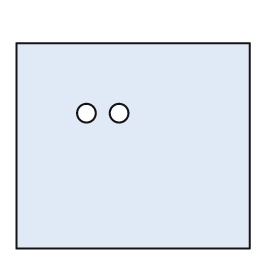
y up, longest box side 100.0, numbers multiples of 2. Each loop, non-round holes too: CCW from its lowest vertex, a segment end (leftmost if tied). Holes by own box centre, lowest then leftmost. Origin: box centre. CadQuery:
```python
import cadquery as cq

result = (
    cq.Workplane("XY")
    .moveTo(-50.0, -44.0)
    .lineTo(50.0, -44.0)
    .lineTo(50.0, 44.0)
    .lineTo(-50.0, 44.0)
    .close()
    .moveTo(-20.0, 14.0)
    .circle(4.0)
    .moveTo(-6.0, 14.0)
    .circle(4.0)
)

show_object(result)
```